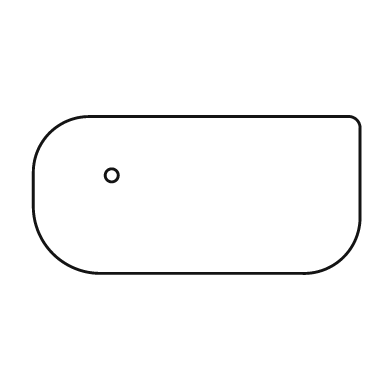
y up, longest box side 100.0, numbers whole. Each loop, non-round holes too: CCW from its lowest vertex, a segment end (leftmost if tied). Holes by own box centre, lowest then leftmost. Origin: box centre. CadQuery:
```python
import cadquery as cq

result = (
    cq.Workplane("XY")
    .moveTo(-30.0, -24.0)
    .lineTo(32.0, -24.0)
    .threePointArc((45.0, -19.0), (50.0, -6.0))
    .lineTo(50.0, 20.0)
    .threePointArc((49.0, 23.0), (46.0, 24.0))
    .lineTo(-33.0, 24.0)
    .threePointArc((-45.0, 19.0), (-50.0, 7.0))
    .lineTo(-50.0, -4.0)
    .threePointArc((-44.0, -18.0), (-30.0, -24.0))
    .close()
    .moveTo(-26.0, 6.0)
    .circle(2.0)
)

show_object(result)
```